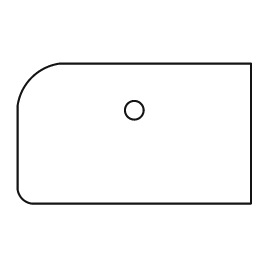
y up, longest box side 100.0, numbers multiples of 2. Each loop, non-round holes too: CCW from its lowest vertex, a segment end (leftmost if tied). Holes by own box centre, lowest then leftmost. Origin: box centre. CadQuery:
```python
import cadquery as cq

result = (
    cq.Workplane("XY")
    .moveTo(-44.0, -30.0)
    .lineTo(50.0, -30.0)
    .lineTo(50.0, 30.0)
    .lineTo(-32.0, 30.0)
    .threePointArc((-44.0, 24.0), (-50.0, 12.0))
    .lineTo(-50.0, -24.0)
    .threePointArc((-48.0, -28.0), (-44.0, -30.0))
    .close()
    .moveTo(0.0, 10.0)
    .circle(4.0)
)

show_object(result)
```